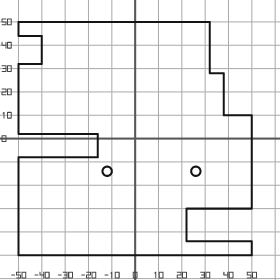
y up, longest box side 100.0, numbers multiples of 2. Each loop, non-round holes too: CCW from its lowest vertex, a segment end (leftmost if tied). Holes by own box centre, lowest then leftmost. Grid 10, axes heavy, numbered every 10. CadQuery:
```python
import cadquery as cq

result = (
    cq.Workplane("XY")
    .moveTo(-50.0, -50.0)
    .lineTo(50.0, -50.0)
    .lineTo(50.0, -44.0)
    .lineTo(22.0, -44.0)
    .lineTo(22.0, -30.0)
    .lineTo(50.0, -30.0)
    .lineTo(50.0, 10.0)
    .lineTo(38.0, 10.0)
    .lineTo(38.0, 28.0)
    .lineTo(32.0, 28.0)
    .lineTo(32.0, 50.0)
    .lineTo(-50.0, 50.0)
    .lineTo(-50.0, 44.0)
    .lineTo(-40.0, 44.0)
    .lineTo(-40.0, 32.0)
    .lineTo(-50.0, 32.0)
    .lineTo(-50.0, 2.0)
    .lineTo(-16.0, 2.0)
    .lineTo(-16.0, -8.0)
    .lineTo(-50.0, -8.0)
    .close()
    .moveTo(-12.0, -14.0)
    .circle(2.0)
    .moveTo(26.0, -14.0)
    .circle(2.0)
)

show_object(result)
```